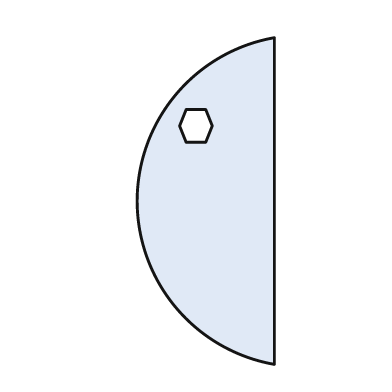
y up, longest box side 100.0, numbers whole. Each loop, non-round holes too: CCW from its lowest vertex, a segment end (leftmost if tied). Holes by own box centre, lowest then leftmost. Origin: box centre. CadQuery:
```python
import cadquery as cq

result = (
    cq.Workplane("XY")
    .moveTo(21.0, -50.0)
    .lineTo(21.0, 50.0)
    .threePointArc((-21.0, 0.0), (21.0, -50.0))
    .close()
    .moveTo(-6.0, 18.0)
    .lineTo(0.0, 18.0)
    .lineTo(2.0, 23.0)
    .lineTo(0.0, 28.0)
    .lineTo(-6.0, 28.0)
    .lineTo(-8.0, 23.0)
    .close()
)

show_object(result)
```